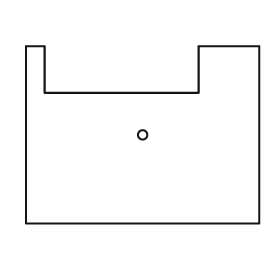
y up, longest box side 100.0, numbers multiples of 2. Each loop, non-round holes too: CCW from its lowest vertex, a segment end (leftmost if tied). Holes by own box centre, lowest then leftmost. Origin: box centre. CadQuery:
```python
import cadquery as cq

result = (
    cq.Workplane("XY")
    .moveTo(-50.0, -38.0)
    .lineTo(50.0, -38.0)
    .lineTo(50.0, 38.0)
    .lineTo(24.0, 38.0)
    .lineTo(24.0, 18.0)
    .lineTo(-42.0, 18.0)
    .lineTo(-42.0, 38.0)
    .lineTo(-50.0, 38.0)
    .close()
    .moveTo(0.0, 0.0)
    .circle(2.0)
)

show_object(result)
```